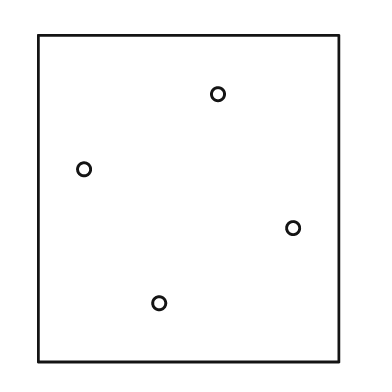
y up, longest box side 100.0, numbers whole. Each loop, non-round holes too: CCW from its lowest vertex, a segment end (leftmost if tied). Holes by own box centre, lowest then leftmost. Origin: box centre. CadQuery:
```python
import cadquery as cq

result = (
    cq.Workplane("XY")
    .moveTo(-46.0, -50.0)
    .lineTo(46.0, -50.0)
    .lineTo(46.0, 50.0)
    .lineTo(-46.0, 50.0)
    .close()
    .moveTo(-9.0, -32.0)
    .circle(2.0)
    .moveTo(32.0, -9.0)
    .circle(2.0)
    .moveTo(-32.0, 9.0)
    .circle(2.0)
    .moveTo(9.0, 32.0)
    .circle(2.0)
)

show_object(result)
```